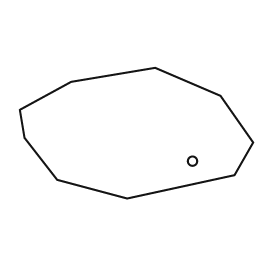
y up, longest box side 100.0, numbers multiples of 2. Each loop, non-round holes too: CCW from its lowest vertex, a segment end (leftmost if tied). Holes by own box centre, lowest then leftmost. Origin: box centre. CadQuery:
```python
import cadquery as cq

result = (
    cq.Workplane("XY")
    .moveTo(-4.0, -28.0)
    .lineTo(42.0, -18.0)
    .lineTo(50.0, -4.0)
    .lineTo(36.0, 16.0)
    .lineTo(8.0, 28.0)
    .lineTo(-28.0, 22.0)
    .lineTo(-50.0, 10.0)
    .lineTo(-48.0, -2.0)
    .lineTo(-34.0, -20.0)
    .close()
    .moveTo(24.0, -12.0)
    .circle(2.0)
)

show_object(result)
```